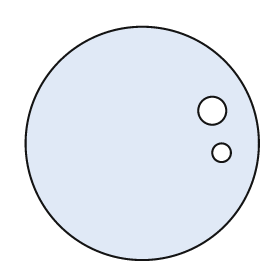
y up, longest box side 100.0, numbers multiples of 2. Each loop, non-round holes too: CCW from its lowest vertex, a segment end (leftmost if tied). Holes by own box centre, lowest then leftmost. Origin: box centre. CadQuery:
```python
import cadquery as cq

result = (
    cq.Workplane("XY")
    .moveTo(0.0, 0.0)
    .circle(50.0)
    .moveTo(34.0, -4.0)
    .circle(4.0)
    .moveTo(30.0, 14.0)
    .circle(6.0)
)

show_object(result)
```